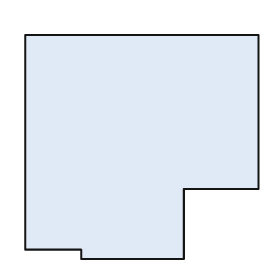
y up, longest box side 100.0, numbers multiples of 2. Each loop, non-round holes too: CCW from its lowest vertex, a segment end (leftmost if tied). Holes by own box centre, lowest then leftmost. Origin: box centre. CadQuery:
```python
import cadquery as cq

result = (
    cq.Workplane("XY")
    .moveTo(-26.0, -48.0)
    .lineTo(18.0, -48.0)
    .lineTo(18.0, -18.0)
    .lineTo(50.0, -18.0)
    .lineTo(50.0, 48.0)
    .lineTo(-50.0, 48.0)
    .lineTo(-50.0, -44.0)
    .lineTo(-26.0, -44.0)
    .close()
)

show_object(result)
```